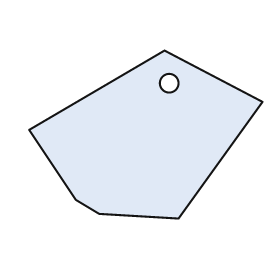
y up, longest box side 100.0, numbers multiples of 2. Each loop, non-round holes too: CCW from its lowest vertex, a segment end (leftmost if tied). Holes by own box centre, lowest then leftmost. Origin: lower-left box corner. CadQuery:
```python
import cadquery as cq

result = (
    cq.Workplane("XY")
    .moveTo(64.0, 0.0)
    .lineTo(100.0, 50.0)
    .lineTo(58.0, 72.0)
    .lineTo(0.0, 38.0)
    .lineTo(20.0, 8.0)
    .lineTo(30.0, 2.0)
    .close()
    .moveTo(60.0, 58.0)
    .circle(4.0)
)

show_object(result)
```